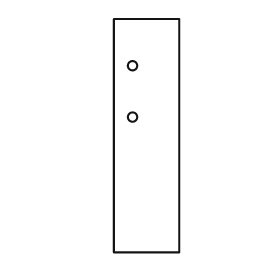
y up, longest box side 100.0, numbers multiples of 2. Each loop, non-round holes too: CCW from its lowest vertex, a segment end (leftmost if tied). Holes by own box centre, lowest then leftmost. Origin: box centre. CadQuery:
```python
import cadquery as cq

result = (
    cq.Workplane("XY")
    .moveTo(-14.0, -50.0)
    .lineTo(14.0, -50.0)
    .lineTo(14.0, 50.0)
    .lineTo(-14.0, 50.0)
    .close()
    .moveTo(-6.0, 8.0)
    .circle(2.0)
    .moveTo(-6.0, 30.0)
    .circle(2.0)
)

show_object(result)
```